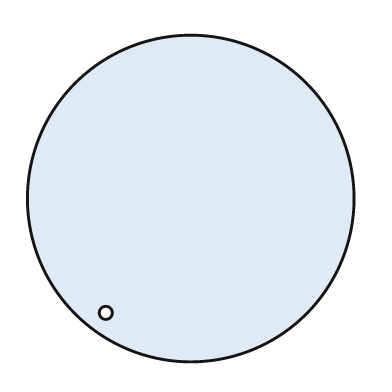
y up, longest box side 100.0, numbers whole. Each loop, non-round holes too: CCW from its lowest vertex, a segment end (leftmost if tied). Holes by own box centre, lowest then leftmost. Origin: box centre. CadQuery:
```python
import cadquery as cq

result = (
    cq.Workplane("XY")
    .moveTo(0.0, 0.0)
    .circle(50.0)
    .moveTo(-26.0, -35.0)
    .circle(2.0)
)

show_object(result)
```